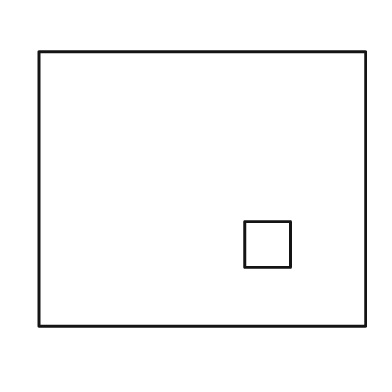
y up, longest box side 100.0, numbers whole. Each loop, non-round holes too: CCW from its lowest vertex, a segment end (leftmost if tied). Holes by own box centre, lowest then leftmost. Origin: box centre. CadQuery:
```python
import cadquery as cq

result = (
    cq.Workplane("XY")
    .moveTo(-50.0, -42.0)
    .lineTo(50.0, -42.0)
    .lineTo(50.0, 42.0)
    .lineTo(-50.0, 42.0)
    .close()
    .moveTo(13.0, -24.0)
    .lineTo(27.0, -24.0)
    .lineTo(27.0, -10.0)
    .lineTo(13.0, -10.0)
    .close()
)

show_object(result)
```